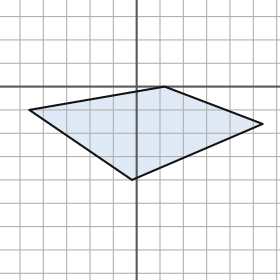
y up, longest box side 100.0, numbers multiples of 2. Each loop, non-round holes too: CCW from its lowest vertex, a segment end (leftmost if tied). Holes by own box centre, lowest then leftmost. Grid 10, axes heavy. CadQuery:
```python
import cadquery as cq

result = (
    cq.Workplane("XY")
    .moveTo(-2.0, -40.0)
    .lineTo(54.0, -16.0)
    .lineTo(12.0, 0.0)
    .lineTo(-46.0, -10.0)
    .close()
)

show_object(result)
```